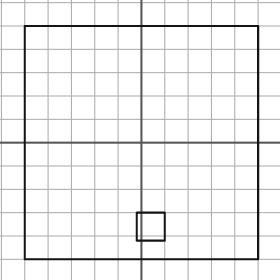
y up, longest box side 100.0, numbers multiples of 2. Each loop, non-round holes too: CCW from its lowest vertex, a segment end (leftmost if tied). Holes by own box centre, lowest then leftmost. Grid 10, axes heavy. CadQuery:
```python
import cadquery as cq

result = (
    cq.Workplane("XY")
    .moveTo(-50.0, -50.0)
    .lineTo(50.0, -50.0)
    .lineTo(50.0, 50.0)
    .lineTo(-50.0, 50.0)
    .close()
    .moveTo(-2.0, -42.0)
    .lineTo(10.0, -42.0)
    .lineTo(10.0, -30.0)
    .lineTo(-2.0, -30.0)
    .close()
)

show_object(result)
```